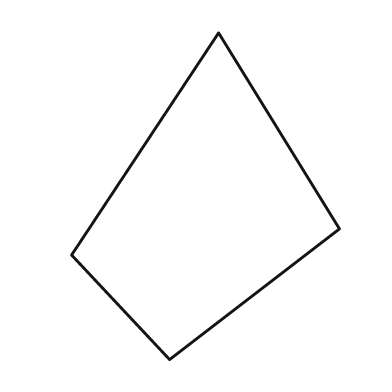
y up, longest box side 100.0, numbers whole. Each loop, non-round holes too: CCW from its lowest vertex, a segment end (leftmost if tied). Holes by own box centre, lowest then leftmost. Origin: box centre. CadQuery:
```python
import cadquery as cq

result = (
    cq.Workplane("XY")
    .moveTo(-11.0, -50.0)
    .lineTo(41.0, -10.0)
    .lineTo(4.0, 50.0)
    .lineTo(-41.0, -18.0)
    .close()
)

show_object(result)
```